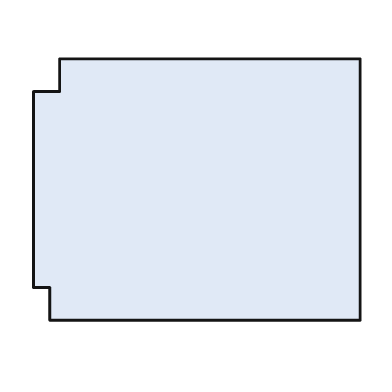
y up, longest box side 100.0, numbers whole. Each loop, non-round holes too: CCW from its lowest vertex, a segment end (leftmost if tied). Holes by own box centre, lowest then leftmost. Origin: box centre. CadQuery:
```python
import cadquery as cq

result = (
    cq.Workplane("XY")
    .moveTo(-45.0, -40.0)
    .lineTo(50.0, -40.0)
    .lineTo(50.0, 40.0)
    .lineTo(-42.0, 40.0)
    .lineTo(-42.0, 30.0)
    .lineTo(-50.0, 30.0)
    .lineTo(-50.0, -30.0)
    .lineTo(-45.0, -30.0)
    .close()
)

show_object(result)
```